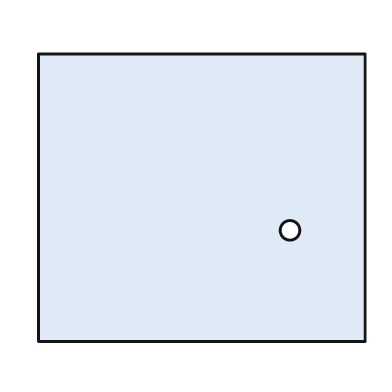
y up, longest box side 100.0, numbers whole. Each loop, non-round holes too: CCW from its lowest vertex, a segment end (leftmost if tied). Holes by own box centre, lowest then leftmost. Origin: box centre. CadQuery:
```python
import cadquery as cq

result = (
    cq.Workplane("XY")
    .moveTo(-50.0, -44.0)
    .lineTo(50.0, -44.0)
    .lineTo(50.0, 44.0)
    .lineTo(-50.0, 44.0)
    .close()
    .moveTo(27.0, -10.0)
    .circle(3.0)
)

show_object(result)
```